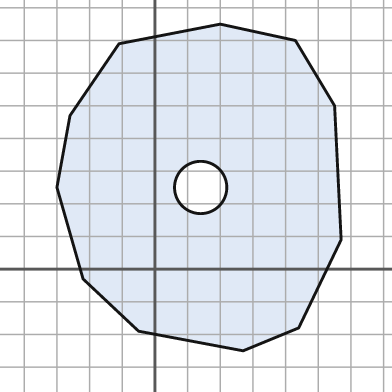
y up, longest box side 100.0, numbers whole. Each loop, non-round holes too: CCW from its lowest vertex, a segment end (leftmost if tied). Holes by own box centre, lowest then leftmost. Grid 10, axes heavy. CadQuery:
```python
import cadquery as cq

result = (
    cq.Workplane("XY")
    .moveTo(27.0, -25.0)
    .lineTo(44.0, -18.0)
    .lineTo(57.0, 9.0)
    .lineTo(55.0, 50.0)
    .lineTo(43.0, 70.0)
    .lineTo(20.0, 75.0)
    .lineTo(-11.0, 69.0)
    .lineTo(-26.0, 47.0)
    .lineTo(-30.0, 25.0)
    .lineTo(-22.0, -3.0)
    .lineTo(-5.0, -19.0)
    .close()
    .moveTo(14.0, 25.0)
    .circle(8.0)
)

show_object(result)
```